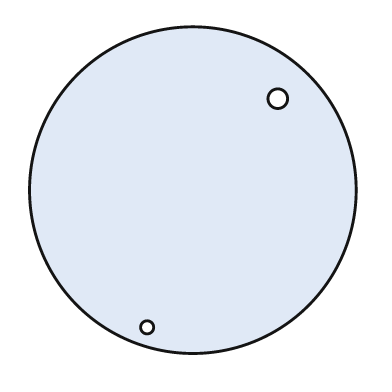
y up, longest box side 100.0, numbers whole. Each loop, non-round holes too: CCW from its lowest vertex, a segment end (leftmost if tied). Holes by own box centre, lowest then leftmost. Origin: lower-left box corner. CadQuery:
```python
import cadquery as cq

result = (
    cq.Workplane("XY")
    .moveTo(50.0, 50.0)
    .circle(50.0)
    .moveTo(36.0, 8.0)
    .circle(2.0)
    .moveTo(76.0, 78.0)
    .circle(3.0)
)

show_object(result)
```